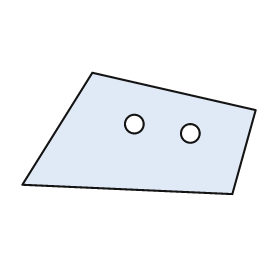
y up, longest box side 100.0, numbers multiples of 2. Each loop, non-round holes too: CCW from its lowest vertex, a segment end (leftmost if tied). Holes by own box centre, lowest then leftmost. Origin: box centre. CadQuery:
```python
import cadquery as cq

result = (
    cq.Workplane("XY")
    .moveTo(40.0, -26.0)
    .lineTo(50.0, 10.0)
    .lineTo(-20.0, 26.0)
    .lineTo(-50.0, -22.0)
    .close()
    .moveTo(22.0, 0.0)
    .circle(4.0)
    .moveTo(-2.0, 4.0)
    .circle(4.0)
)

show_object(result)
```